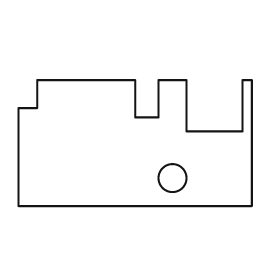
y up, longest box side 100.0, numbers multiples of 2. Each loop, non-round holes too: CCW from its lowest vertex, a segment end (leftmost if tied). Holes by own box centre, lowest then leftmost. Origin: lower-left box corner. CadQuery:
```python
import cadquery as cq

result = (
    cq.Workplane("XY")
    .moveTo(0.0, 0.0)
    .lineTo(100.0, 0.0)
    .lineTo(100.0, 54.0)
    .lineTo(96.0, 54.0)
    .lineTo(96.0, 32.0)
    .lineTo(72.0, 32.0)
    .lineTo(72.0, 54.0)
    .lineTo(60.0, 54.0)
    .lineTo(60.0, 38.0)
    .lineTo(50.0, 38.0)
    .lineTo(50.0, 54.0)
    .lineTo(8.0, 54.0)
    .lineTo(8.0, 42.0)
    .lineTo(0.0, 42.0)
    .close()
    .moveTo(66.0, 12.0)
    .circle(6.0)
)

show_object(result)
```